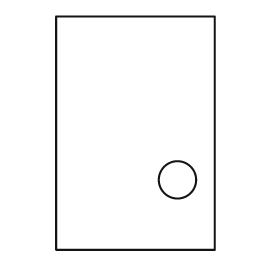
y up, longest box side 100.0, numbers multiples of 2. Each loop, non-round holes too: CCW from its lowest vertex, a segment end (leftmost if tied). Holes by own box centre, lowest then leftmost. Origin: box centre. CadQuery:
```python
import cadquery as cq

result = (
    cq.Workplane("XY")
    .moveTo(-34.0, -50.0)
    .lineTo(34.0, -50.0)
    .lineTo(34.0, 50.0)
    .lineTo(-34.0, 50.0)
    .close()
    .moveTo(18.0, -20.0)
    .circle(8.0)
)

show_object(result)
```